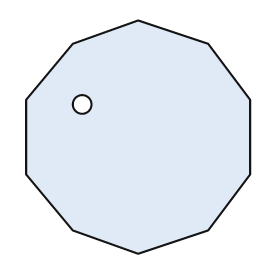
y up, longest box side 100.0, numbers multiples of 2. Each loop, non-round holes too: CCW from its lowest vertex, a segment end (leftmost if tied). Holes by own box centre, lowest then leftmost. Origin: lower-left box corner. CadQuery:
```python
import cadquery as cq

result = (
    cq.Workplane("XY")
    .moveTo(48.0, 0.0)
    .lineTo(78.0, 10.0)
    .lineTo(96.0, 34.0)
    .lineTo(96.0, 66.0)
    .lineTo(78.0, 90.0)
    .lineTo(48.0, 100.0)
    .lineTo(20.0, 90.0)
    .lineTo(0.0, 66.0)
    .lineTo(0.0, 34.0)
    .lineTo(20.0, 10.0)
    .close()
    .moveTo(24.0, 64.0)
    .circle(4.0)
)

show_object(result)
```